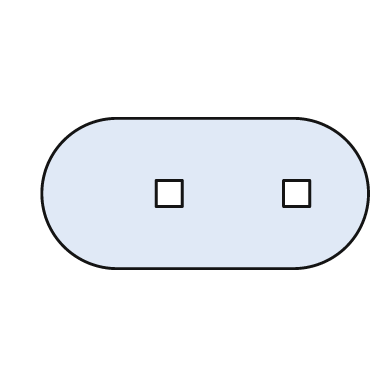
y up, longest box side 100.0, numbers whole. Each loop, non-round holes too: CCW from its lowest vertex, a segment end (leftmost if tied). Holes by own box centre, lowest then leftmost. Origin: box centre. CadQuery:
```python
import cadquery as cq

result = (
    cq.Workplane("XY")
    .moveTo(-27.0, -23.0)
    .lineTo(27.0, -23.0)
    .threePointArc((50.0, 0.0), (27.0, 23.0))
    .lineTo(-27.0, 23.0)
    .threePointArc((-50.0, 0.0), (-27.0, -23.0))
    .close()
    .moveTo(-15.0, -4.0)
    .lineTo(-7.0, -4.0)
    .lineTo(-7.0, 4.0)
    .lineTo(-15.0, 4.0)
    .close()
    .moveTo(24.0, -4.0)
    .lineTo(32.0, -4.0)
    .lineTo(32.0, 4.0)
    .lineTo(24.0, 4.0)
    .close()
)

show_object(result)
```